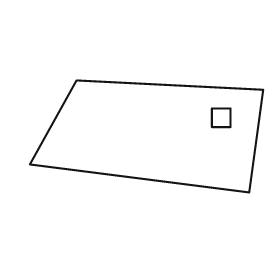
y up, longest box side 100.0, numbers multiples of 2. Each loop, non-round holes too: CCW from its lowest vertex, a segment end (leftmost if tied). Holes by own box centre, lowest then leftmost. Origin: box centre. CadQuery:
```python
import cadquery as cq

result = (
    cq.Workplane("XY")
    .moveTo(44.0, -24.0)
    .lineTo(50.0, 20.0)
    .lineTo(-30.0, 24.0)
    .lineTo(-50.0, -12.0)
    .close()
    .moveTo(28.0, 4.0)
    .lineTo(36.0, 4.0)
    .lineTo(36.0, 12.0)
    .lineTo(28.0, 12.0)
    .close()
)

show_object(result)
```